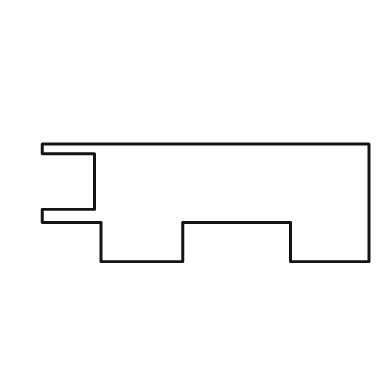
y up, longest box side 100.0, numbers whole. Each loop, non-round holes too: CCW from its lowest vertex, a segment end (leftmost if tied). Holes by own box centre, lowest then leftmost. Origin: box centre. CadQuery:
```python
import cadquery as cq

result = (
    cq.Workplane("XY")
    .moveTo(-32.0, -18.0)
    .lineTo(-7.0, -18.0)
    .lineTo(-7.0, -6.0)
    .lineTo(26.0, -6.0)
    .lineTo(26.0, -18.0)
    .lineTo(50.0, -18.0)
    .lineTo(50.0, 18.0)
    .lineTo(-50.0, 18.0)
    .lineTo(-50.0, 15.0)
    .lineTo(-34.0, 15.0)
    .lineTo(-34.0, -2.0)
    .lineTo(-50.0, -2.0)
    .lineTo(-50.0, -6.0)
    .lineTo(-32.0, -6.0)
    .close()
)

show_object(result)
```